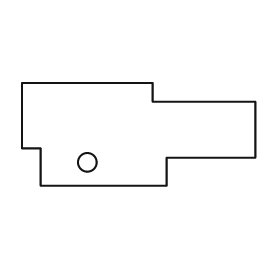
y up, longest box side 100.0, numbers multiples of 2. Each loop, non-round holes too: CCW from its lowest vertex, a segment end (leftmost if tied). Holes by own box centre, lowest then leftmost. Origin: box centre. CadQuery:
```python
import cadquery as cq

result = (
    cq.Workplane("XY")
    .moveTo(-42.0, -22.0)
    .lineTo(12.0, -22.0)
    .lineTo(12.0, -10.0)
    .lineTo(50.0, -10.0)
    .lineTo(50.0, 14.0)
    .lineTo(6.0, 14.0)
    .lineTo(6.0, 22.0)
    .lineTo(-50.0, 22.0)
    .lineTo(-50.0, -6.0)
    .lineTo(-42.0, -6.0)
    .close()
    .moveTo(-22.0, -12.0)
    .circle(4.0)
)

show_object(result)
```